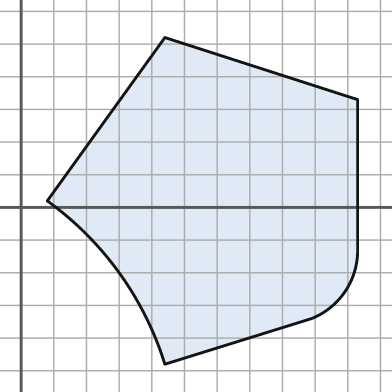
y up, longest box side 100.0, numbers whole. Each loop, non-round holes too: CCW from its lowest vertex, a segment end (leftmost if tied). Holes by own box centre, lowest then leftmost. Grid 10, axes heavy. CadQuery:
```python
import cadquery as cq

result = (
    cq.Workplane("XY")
    .moveTo(44.0, -48.0)
    .lineTo(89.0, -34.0)
    .threePointArc((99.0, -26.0), (103.0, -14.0))
    .lineTo(103.0, 33.0)
    .lineTo(44.0, 52.0)
    .lineTo(8.0, 2.0)
    .threePointArc((30.0, -20.0), (44.0, -48.0))
    .close()
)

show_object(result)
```